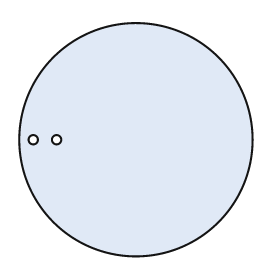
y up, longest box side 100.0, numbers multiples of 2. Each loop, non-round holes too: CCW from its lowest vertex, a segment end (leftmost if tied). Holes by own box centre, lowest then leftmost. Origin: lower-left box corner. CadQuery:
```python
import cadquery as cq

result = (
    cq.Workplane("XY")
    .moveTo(50.0, 50.0)
    .circle(50.0)
    .moveTo(6.0, 50.0)
    .circle(2.0)
    .moveTo(16.0, 50.0)
    .circle(2.0)
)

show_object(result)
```